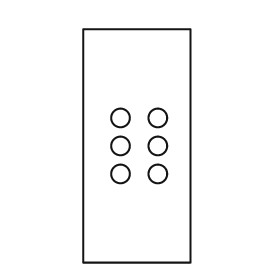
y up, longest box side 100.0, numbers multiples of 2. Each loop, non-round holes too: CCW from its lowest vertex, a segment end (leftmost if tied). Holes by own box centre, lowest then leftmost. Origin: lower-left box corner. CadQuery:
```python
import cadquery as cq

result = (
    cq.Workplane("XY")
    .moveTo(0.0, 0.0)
    .lineTo(46.0, 0.0)
    .lineTo(46.0, 100.0)
    .lineTo(0.0, 100.0)
    .close()
    .moveTo(16.0, 38.0)
    .circle(4.0)
    .moveTo(32.0, 38.0)
    .circle(4.0)
    .moveTo(16.0, 50.0)
    .circle(4.0)
    .moveTo(32.0, 50.0)
    .circle(4.0)
    .moveTo(16.0, 62.0)
    .circle(4.0)
    .moveTo(32.0, 62.0)
    .circle(4.0)
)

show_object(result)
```